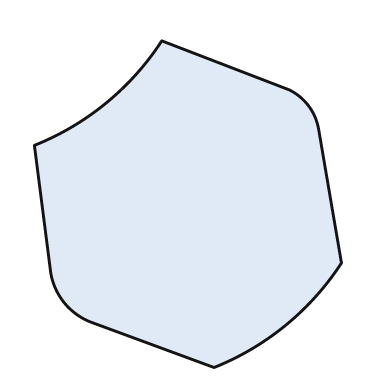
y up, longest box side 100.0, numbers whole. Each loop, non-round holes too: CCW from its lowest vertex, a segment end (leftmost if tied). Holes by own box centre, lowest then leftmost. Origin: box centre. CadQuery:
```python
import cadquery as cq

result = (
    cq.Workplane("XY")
    .moveTo(8.0, -50.0)
    .threePointArc((30.0, -37.0), (47.0, -18.0))
    .lineTo(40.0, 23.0)
    .threePointArc((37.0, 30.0), (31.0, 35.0))
    .lineTo(-8.0, 50.0)
    .threePointArc((-25.0, 31.0), (-47.0, 18.0))
    .lineTo(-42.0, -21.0)
    .threePointArc((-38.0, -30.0), (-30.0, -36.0))
    .close()
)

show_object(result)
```